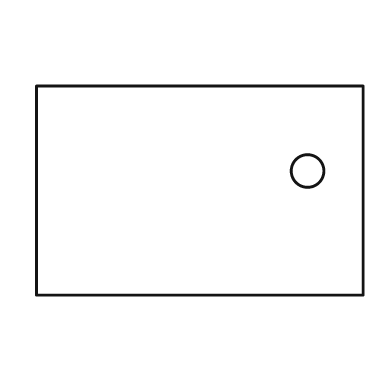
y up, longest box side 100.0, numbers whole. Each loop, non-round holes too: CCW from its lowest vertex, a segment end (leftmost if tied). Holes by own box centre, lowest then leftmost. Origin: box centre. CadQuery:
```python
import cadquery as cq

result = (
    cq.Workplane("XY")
    .moveTo(-50.0, -32.0)
    .lineTo(50.0, -32.0)
    .lineTo(50.0, 32.0)
    .lineTo(-50.0, 32.0)
    .close()
    .moveTo(33.0, 6.0)
    .circle(5.0)
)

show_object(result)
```